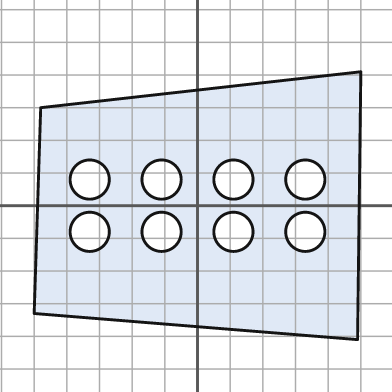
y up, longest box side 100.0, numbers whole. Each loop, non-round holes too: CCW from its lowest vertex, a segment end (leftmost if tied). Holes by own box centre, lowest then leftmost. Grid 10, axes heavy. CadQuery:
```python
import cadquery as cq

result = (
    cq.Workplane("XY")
    .moveTo(49.0, -41.0)
    .lineTo(50.0, 41.0)
    .lineTo(-48.0, 30.0)
    .lineTo(-50.0, -33.0)
    .close()
    .moveTo(-33.0, -8.0)
    .circle(6.0)
    .moveTo(-11.0, -8.0)
    .circle(6.0)
    .moveTo(11.0, -8.0)
    .circle(6.0)
    .moveTo(33.0, -8.0)
    .circle(6.0)
    .moveTo(-33.0, 8.0)
    .circle(6.0)
    .moveTo(-11.0, 8.0)
    .circle(6.0)
    .moveTo(11.0, 8.0)
    .circle(6.0)
    .moveTo(33.0, 8.0)
    .circle(6.0)
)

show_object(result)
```